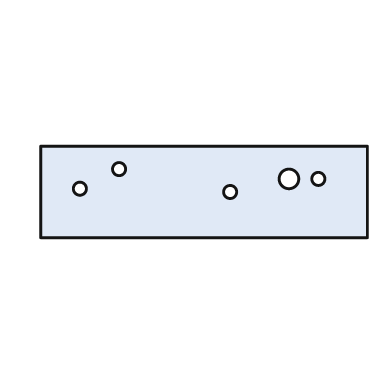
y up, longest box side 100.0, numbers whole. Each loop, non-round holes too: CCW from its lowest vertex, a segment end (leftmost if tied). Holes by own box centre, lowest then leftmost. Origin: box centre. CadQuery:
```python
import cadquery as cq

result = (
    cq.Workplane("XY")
    .moveTo(-50.0, -14.0)
    .lineTo(50.0, -14.0)
    .lineTo(50.0, 14.0)
    .lineTo(-50.0, 14.0)
    .close()
    .moveTo(8.0, 0.0)
    .circle(2.0)
    .moveTo(-38.0, 1.0)
    .circle(2.0)
    .moveTo(26.0, 4.0)
    .circle(3.0)
    .moveTo(35.0, 4.0)
    .circle(2.0)
    .moveTo(-26.0, 7.0)
    .circle(2.0)
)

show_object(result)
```